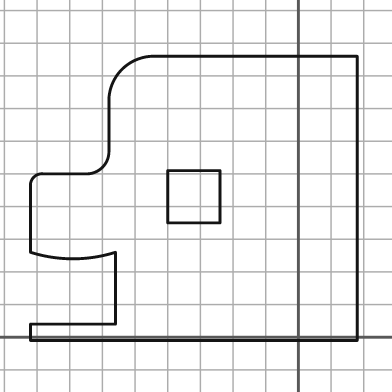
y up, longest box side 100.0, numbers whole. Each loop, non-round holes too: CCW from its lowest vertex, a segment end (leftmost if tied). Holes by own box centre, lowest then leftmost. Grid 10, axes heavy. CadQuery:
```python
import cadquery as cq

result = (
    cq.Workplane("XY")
    .moveTo(-82.0, -1.0)
    .lineTo(18.0, -1.0)
    .lineTo(18.0, 86.0)
    .lineTo(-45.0, 86.0)
    .threePointArc((-54.0, 82.0), (-58.0, 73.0))
    .lineTo(-58.0, 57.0)
    .threePointArc((-60.0, 52.0), (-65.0, 50.0))
    .lineTo(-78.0, 50.0)
    .threePointArc((-81.0, 49.0), (-82.0, 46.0))
    .lineTo(-82.0, 26.0)
    .threePointArc((-69.0, 24.0), (-56.0, 26.0))
    .lineTo(-56.0, 4.0)
    .lineTo(-82.0, 4.0)
    .close()
    .moveTo(-40.0, 35.0)
    .lineTo(-24.0, 35.0)
    .lineTo(-24.0, 51.0)
    .lineTo(-40.0, 51.0)
    .close()
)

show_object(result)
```